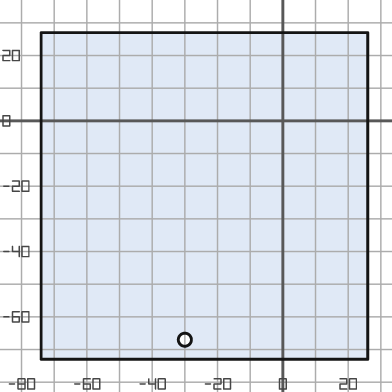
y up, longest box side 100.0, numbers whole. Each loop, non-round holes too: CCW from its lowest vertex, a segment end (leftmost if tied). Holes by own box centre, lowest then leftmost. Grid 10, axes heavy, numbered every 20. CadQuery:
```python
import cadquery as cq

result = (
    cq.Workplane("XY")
    .moveTo(-74.0, -73.0)
    .lineTo(26.0, -73.0)
    .lineTo(26.0, 27.0)
    .lineTo(-74.0, 27.0)
    .close()
    .moveTo(-30.0, -67.0)
    .circle(2.0)
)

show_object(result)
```